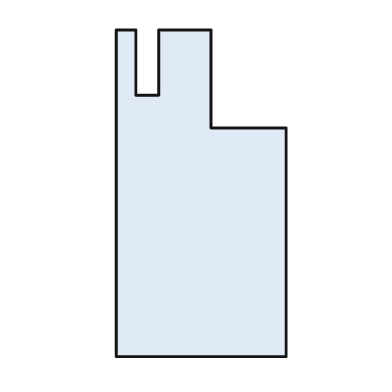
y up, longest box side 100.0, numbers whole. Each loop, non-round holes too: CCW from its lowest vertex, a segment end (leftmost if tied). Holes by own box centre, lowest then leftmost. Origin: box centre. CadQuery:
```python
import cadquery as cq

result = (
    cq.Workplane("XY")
    .moveTo(-26.0, -50.0)
    .lineTo(26.0, -50.0)
    .lineTo(26.0, 20.0)
    .lineTo(3.0, 20.0)
    .lineTo(3.0, 50.0)
    .lineTo(-13.0, 50.0)
    .lineTo(-13.0, 30.0)
    .lineTo(-20.0, 30.0)
    .lineTo(-20.0, 50.0)
    .lineTo(-26.0, 50.0)
    .close()
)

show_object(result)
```